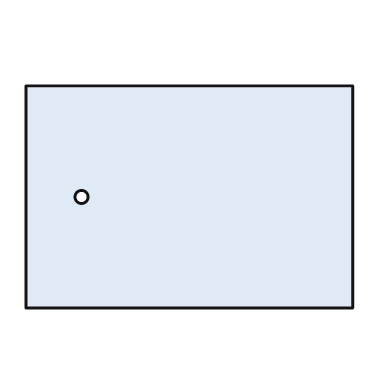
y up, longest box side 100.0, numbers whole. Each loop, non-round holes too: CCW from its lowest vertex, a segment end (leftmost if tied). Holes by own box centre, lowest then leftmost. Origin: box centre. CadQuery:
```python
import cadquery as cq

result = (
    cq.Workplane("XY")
    .moveTo(-50.0, -34.0)
    .lineTo(50.0, -34.0)
    .lineTo(50.0, 34.0)
    .lineTo(-50.0, 34.0)
    .close()
    .moveTo(-33.0, 0.0)
    .circle(2.0)
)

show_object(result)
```